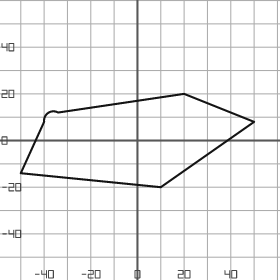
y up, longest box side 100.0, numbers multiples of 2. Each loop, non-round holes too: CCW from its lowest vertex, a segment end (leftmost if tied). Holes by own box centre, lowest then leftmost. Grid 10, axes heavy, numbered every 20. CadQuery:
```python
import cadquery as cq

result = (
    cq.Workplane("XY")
    .moveTo(10.0, -20.0)
    .lineTo(50.0, 8.0)
    .lineTo(20.0, 20.0)
    .lineTo(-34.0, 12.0)
    .threePointArc((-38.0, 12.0), (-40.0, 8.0))
    .lineTo(-50.0, -14.0)
    .close()
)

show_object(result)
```